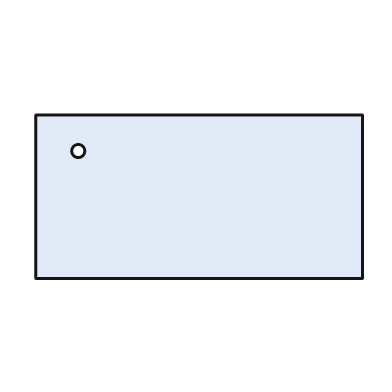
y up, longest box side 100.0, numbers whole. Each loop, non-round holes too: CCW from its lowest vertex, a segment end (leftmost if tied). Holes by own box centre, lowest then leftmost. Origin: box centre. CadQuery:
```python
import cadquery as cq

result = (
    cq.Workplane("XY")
    .moveTo(-50.0, -25.0)
    .lineTo(50.0, -25.0)
    .lineTo(50.0, 25.0)
    .lineTo(-50.0, 25.0)
    .close()
    .moveTo(-37.0, 14.0)
    .circle(2.0)
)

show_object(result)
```